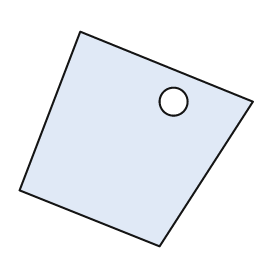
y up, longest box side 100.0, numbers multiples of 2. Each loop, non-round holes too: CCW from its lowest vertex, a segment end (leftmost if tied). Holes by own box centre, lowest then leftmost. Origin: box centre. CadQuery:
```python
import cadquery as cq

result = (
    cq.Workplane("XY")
    .moveTo(10.0, -46.0)
    .lineTo(50.0, 16.0)
    .lineTo(-24.0, 46.0)
    .lineTo(-50.0, -22.0)
    .close()
    .moveTo(16.0, 16.0)
    .circle(6.0)
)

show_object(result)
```